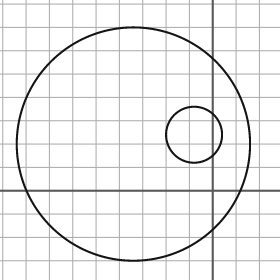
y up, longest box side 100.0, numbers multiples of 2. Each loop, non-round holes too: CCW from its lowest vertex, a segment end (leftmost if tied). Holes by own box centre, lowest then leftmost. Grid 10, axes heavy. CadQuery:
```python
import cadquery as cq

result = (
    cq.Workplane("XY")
    .moveTo(-34.0, 20.0)
    .circle(50.0)
    .moveTo(-8.0, 24.0)
    .circle(12.0)
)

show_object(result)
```